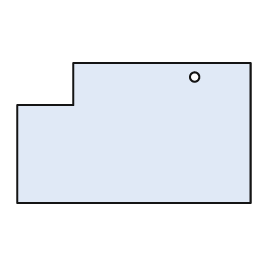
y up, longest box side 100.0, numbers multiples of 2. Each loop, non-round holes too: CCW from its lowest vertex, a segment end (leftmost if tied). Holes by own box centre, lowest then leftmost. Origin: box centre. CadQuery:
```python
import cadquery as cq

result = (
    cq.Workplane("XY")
    .moveTo(-50.0, -30.0)
    .lineTo(50.0, -30.0)
    .lineTo(50.0, 30.0)
    .lineTo(-26.0, 30.0)
    .lineTo(-26.0, 12.0)
    .lineTo(-50.0, 12.0)
    .close()
    .moveTo(26.0, 24.0)
    .circle(2.0)
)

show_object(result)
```